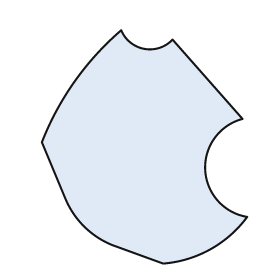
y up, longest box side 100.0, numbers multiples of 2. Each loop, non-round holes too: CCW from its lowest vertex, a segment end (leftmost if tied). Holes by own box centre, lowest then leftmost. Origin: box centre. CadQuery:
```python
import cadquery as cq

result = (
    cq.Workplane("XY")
    .moveTo(8.0, -50.0)
    .threePointArc((28.0, -44.0), (44.0, -30.0))
    .threePointArc((26.0, -10.0), (42.0, 12.0))
    .lineTo(12.0, 46.0)
    .threePointArc((0.0, 42.0), (-10.0, 50.0))
    .threePointArc((-30.0, 28.0), (-44.0, 2.0))
    .lineTo(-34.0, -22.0)
    .threePointArc((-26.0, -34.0), (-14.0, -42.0))
    .close()
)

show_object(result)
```